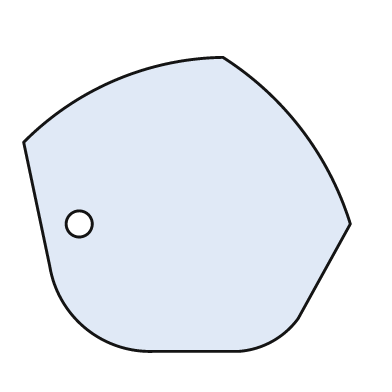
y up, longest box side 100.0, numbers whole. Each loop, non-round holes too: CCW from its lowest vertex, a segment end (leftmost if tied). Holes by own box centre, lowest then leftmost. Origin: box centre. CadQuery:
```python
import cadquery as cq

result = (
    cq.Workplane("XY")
    .moveTo(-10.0, -45.0)
    .lineTo(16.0, -45.0)
    .threePointArc((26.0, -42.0), (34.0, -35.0))
    .lineTo(50.0, -6.0)
    .threePointArc((35.0, 23.0), (11.0, 45.0))
    .threePointArc((-22.0, 38.0), (-50.0, 19.0))
    .lineTo(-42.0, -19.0)
    .threePointArc((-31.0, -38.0), (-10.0, -45.0))
    .close()
    .moveTo(-33.0, -6.0)
    .circle(4.0)
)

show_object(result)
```